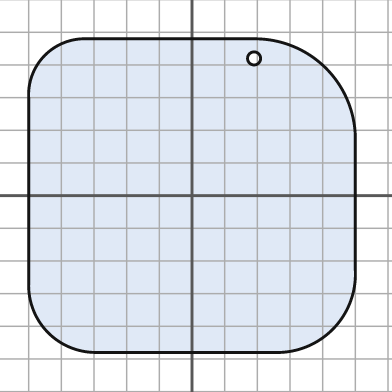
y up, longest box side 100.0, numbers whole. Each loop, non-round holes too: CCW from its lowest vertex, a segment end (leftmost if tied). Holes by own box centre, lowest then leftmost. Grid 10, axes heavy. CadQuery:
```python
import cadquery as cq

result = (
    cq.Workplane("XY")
    .moveTo(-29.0, -48.0)
    .lineTo(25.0, -48.0)
    .threePointArc((43.0, -41.0), (50.0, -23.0))
    .lineTo(50.0, 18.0)
    .threePointArc((41.0, 39.0), (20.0, 48.0))
    .lineTo(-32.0, 48.0)
    .threePointArc((-45.0, 43.0), (-50.0, 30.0))
    .lineTo(-50.0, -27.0)
    .threePointArc((-44.0, -42.0), (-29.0, -48.0))
    .close()
    .moveTo(19.0, 42.0)
    .circle(2.0)
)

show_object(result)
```